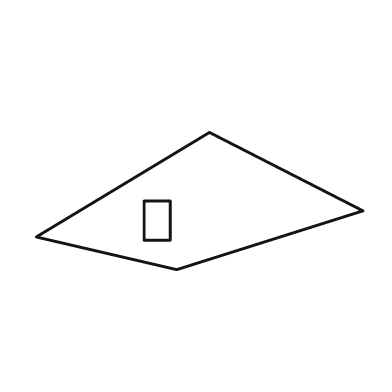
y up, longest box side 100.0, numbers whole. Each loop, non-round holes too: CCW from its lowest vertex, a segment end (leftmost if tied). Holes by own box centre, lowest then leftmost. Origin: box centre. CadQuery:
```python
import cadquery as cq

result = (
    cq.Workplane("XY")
    .moveTo(-7.0, -21.0)
    .lineTo(50.0, -3.0)
    .lineTo(3.0, 21.0)
    .lineTo(-50.0, -11.0)
    .close()
    .moveTo(-17.0, -12.0)
    .lineTo(-9.0, -12.0)
    .lineTo(-9.0, 0.0)
    .lineTo(-17.0, 0.0)
    .close()
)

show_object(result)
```